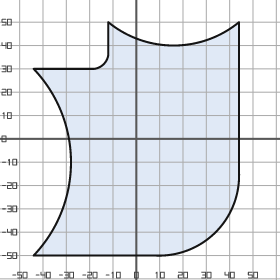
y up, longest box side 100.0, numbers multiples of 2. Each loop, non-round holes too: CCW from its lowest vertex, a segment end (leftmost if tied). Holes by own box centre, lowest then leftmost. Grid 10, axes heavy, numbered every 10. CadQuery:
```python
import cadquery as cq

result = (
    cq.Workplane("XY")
    .moveTo(-44.0, -50.0)
    .lineTo(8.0, -50.0)
    .threePointArc((34.0, -40.0), (44.0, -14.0))
    .lineTo(44.0, 50.0)
    .threePointArc((16.0, 40.0), (-12.0, 50.0))
    .lineTo(-12.0, 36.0)
    .threePointArc((-14.0, 32.0), (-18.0, 30.0))
    .lineTo(-44.0, 30.0)
    .threePointArc((-28.0, -10.0), (-44.0, -50.0))
    .close()
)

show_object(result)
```